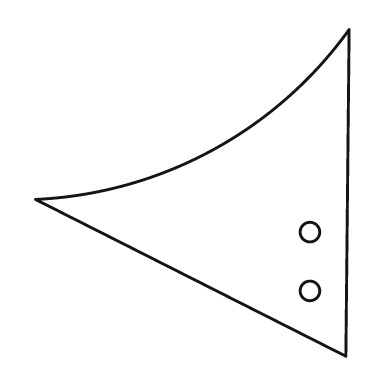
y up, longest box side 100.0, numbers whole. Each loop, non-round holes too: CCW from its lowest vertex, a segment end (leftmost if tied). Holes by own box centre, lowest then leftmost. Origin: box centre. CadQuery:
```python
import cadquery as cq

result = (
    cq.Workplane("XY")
    .moveTo(47.0, -50.0)
    .lineTo(48.0, 50.0)
    .threePointArc((6.0, 13.0), (-48.0, -2.0))
    .close()
    .moveTo(36.0, -30.0)
    .circle(3.0)
    .moveTo(36.0, -12.0)
    .circle(3.0)
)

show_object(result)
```